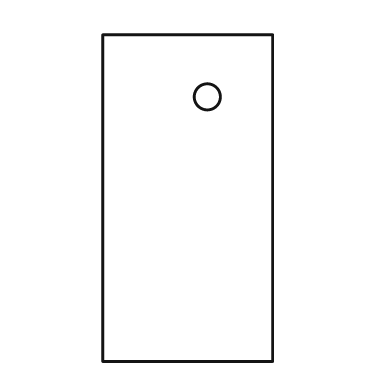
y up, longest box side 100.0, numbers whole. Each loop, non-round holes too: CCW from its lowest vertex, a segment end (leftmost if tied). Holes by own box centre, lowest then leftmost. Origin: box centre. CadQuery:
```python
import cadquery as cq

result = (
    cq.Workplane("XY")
    .moveTo(-26.0, -50.0)
    .lineTo(26.0, -50.0)
    .lineTo(26.0, 50.0)
    .lineTo(-26.0, 50.0)
    .close()
    .moveTo(6.0, 31.0)
    .circle(4.0)
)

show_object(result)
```